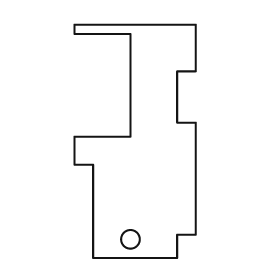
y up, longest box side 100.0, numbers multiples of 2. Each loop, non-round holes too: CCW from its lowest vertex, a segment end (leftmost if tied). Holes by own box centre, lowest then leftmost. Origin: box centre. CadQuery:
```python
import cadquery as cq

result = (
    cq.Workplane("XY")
    .moveTo(-18.0, -50.0)
    .lineTo(18.0, -50.0)
    .lineTo(18.0, -40.0)
    .lineTo(26.0, -40.0)
    .lineTo(26.0, 8.0)
    .lineTo(18.0, 8.0)
    .lineTo(18.0, 30.0)
    .lineTo(26.0, 30.0)
    .lineTo(26.0, 50.0)
    .lineTo(-26.0, 50.0)
    .lineTo(-26.0, 46.0)
    .lineTo(-2.0, 46.0)
    .lineTo(-2.0, 2.0)
    .lineTo(-26.0, 2.0)
    .lineTo(-26.0, -10.0)
    .lineTo(-18.0, -10.0)
    .close()
    .moveTo(-2.0, -42.0)
    .circle(4.0)
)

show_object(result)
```